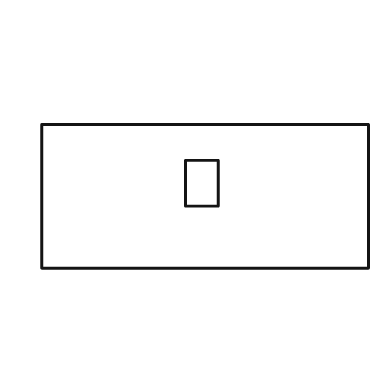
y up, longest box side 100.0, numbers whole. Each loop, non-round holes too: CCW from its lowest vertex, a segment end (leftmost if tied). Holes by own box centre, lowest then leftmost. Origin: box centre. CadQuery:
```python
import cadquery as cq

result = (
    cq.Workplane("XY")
    .moveTo(-50.0, -22.0)
    .lineTo(50.0, -22.0)
    .lineTo(50.0, 22.0)
    .lineTo(-50.0, 22.0)
    .close()
    .moveTo(-6.0, -3.0)
    .lineTo(4.0, -3.0)
    .lineTo(4.0, 11.0)
    .lineTo(-6.0, 11.0)
    .close()
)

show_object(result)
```